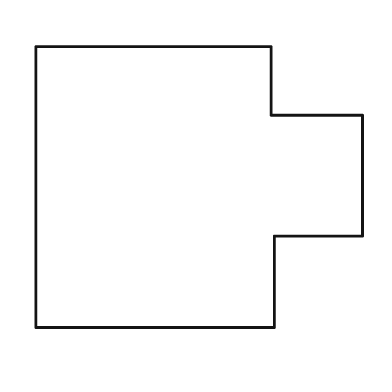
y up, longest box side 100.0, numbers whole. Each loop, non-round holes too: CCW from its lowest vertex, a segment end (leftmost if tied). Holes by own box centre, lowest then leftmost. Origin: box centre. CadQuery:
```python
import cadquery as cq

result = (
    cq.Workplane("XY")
    .moveTo(-50.0, -43.0)
    .lineTo(23.0, -43.0)
    .lineTo(23.0, -15.0)
    .lineTo(50.0, -15.0)
    .lineTo(50.0, 22.0)
    .lineTo(22.0, 22.0)
    .lineTo(22.0, 43.0)
    .lineTo(-50.0, 43.0)
    .close()
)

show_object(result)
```